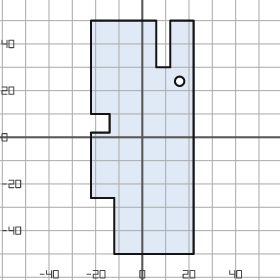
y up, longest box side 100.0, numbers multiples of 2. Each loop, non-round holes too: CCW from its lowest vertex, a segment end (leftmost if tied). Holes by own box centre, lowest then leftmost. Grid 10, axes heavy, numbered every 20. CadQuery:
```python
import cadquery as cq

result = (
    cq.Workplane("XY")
    .moveTo(-12.0, -50.0)
    .lineTo(22.0, -50.0)
    .lineTo(22.0, 50.0)
    .lineTo(12.0, 50.0)
    .lineTo(12.0, 30.0)
    .lineTo(6.0, 30.0)
    .lineTo(6.0, 50.0)
    .lineTo(-22.0, 50.0)
    .lineTo(-22.0, 10.0)
    .lineTo(-14.0, 10.0)
    .lineTo(-14.0, 2.0)
    .lineTo(-22.0, 2.0)
    .lineTo(-22.0, -26.0)
    .lineTo(-12.0, -26.0)
    .close()
    .moveTo(16.0, 24.0)
    .circle(2.0)
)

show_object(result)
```